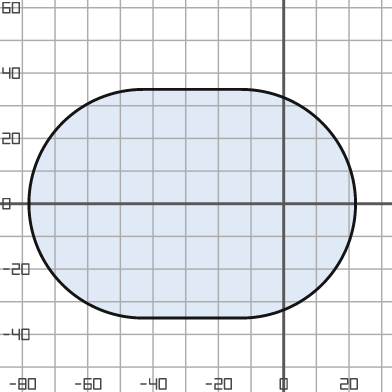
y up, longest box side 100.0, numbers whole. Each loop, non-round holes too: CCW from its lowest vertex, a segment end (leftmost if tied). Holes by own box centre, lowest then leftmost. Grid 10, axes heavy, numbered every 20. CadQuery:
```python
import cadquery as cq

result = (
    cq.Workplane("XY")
    .moveTo(-43.0, -35.0)
    .lineTo(-13.0, -35.0)
    .threePointArc((22.0, 0.0), (-13.0, 35.0))
    .lineTo(-43.0, 35.0)
    .threePointArc((-78.0, 0.0), (-43.0, -35.0))
    .close()
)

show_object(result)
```